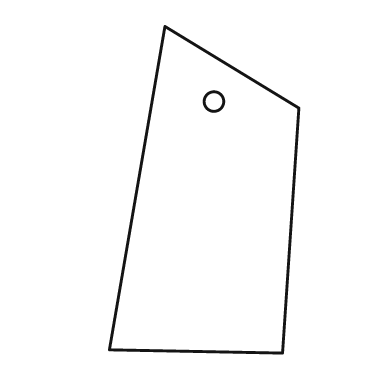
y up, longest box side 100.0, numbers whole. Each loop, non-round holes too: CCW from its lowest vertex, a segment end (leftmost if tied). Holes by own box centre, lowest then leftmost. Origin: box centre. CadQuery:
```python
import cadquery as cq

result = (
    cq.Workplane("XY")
    .moveTo(24.0, -50.0)
    .lineTo(29.0, 25.0)
    .lineTo(-12.0, 50.0)
    .lineTo(-29.0, -49.0)
    .close()
    .moveTo(3.0, 27.0)
    .circle(3.0)
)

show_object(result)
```